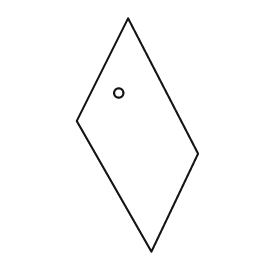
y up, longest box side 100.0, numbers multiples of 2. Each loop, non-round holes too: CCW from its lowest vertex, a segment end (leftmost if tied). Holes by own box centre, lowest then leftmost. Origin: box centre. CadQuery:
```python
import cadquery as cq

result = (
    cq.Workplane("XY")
    .moveTo(6.0, -50.0)
    .lineTo(26.0, -8.0)
    .lineTo(-4.0, 50.0)
    .lineTo(-26.0, 6.0)
    .close()
    .moveTo(-8.0, 18.0)
    .circle(2.0)
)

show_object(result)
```